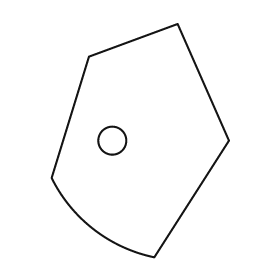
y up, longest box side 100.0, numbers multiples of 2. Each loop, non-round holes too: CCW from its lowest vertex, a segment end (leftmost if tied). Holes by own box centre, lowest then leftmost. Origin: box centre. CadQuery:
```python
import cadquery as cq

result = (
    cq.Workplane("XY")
    .moveTo(6.0, -50.0)
    .lineTo(38.0, 0.0)
    .lineTo(16.0, 50.0)
    .lineTo(-22.0, 36.0)
    .lineTo(-38.0, -16.0)
    .threePointArc((-20.0, -38.0), (6.0, -50.0))
    .close()
    .moveTo(-12.0, 0.0)
    .circle(6.0)
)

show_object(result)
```